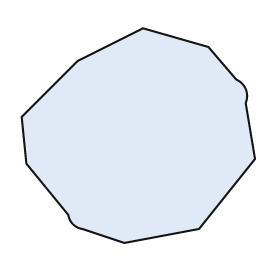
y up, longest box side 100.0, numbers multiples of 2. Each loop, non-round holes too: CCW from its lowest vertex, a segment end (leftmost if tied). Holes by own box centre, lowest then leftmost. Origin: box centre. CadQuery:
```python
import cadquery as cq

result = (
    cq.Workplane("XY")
    .moveTo(-6.0, -46.0)
    .lineTo(26.0, -40.0)
    .lineTo(50.0, -10.0)
    .lineTo(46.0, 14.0)
    .threePointArc((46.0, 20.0), (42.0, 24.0))
    .lineTo(30.0, 38.0)
    .lineTo(2.0, 46.0)
    .lineTo(-26.0, 32.0)
    .lineTo(-50.0, 8.0)
    .lineTo(-48.0, -12.0)
    .lineTo(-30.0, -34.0)
    .threePointArc((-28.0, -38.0), (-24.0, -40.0))
    .close()
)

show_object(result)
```